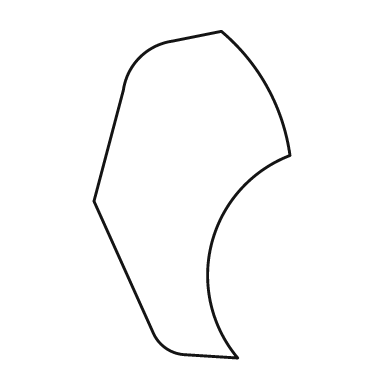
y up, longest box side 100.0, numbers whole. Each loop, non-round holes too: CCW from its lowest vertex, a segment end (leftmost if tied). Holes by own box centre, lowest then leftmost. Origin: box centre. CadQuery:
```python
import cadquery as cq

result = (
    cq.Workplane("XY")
    .moveTo(14.0, -50.0)
    .threePointArc((6.0, -15.0), (30.0, 12.0))
    .threePointArc((23.0, 33.0), (9.0, 50.0))
    .lineTo(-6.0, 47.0)
    .threePointArc((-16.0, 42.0), (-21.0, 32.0))
    .lineTo(-30.0, -2.0)
    .lineTo(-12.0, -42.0)
    .threePointArc((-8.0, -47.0), (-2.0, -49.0))
    .close()
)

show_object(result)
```